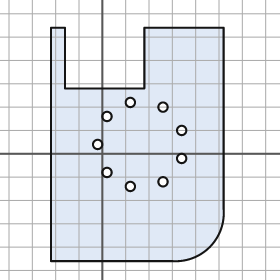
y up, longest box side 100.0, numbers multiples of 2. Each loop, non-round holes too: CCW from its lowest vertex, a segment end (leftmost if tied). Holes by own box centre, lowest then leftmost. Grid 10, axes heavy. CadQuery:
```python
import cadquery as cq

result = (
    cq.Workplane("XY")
    .moveTo(-22.0, -46.0)
    .lineTo(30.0, -46.0)
    .threePointArc((46.0, -40.0), (52.0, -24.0))
    .lineTo(52.0, 54.0)
    .lineTo(18.0, 54.0)
    .lineTo(18.0, 28.0)
    .lineTo(-16.0, 28.0)
    .lineTo(-16.0, 54.0)
    .lineTo(-22.0, 54.0)
    .close()
    .moveTo(12.0, -14.0)
    .circle(2.0)
    .moveTo(26.0, -12.0)
    .circle(2.0)
    .moveTo(2.0, -8.0)
    .circle(2.0)
    .moveTo(34.0, -2.0)
    .circle(2.0)
    .moveTo(-2.0, 4.0)
    .circle(2.0)
    .moveTo(34.0, 10.0)
    .circle(2.0)
    .moveTo(2.0, 16.0)
    .circle(2.0)
    .moveTo(26.0, 20.0)
    .circle(2.0)
    .moveTo(12.0, 22.0)
    .circle(2.0)
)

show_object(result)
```